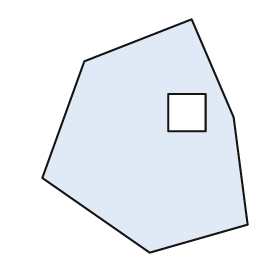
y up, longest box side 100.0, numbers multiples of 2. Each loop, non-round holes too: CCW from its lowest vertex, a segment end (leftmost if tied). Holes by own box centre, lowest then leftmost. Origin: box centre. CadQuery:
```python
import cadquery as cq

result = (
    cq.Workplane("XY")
    .moveTo(2.0, -50.0)
    .lineTo(44.0, -38.0)
    .lineTo(38.0, 8.0)
    .lineTo(20.0, 50.0)
    .lineTo(-26.0, 32.0)
    .lineTo(-44.0, -18.0)
    .close()
    .moveTo(10.0, 2.0)
    .lineTo(26.0, 2.0)
    .lineTo(26.0, 18.0)
    .lineTo(10.0, 18.0)
    .close()
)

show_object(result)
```